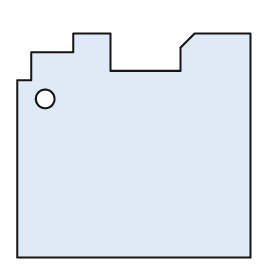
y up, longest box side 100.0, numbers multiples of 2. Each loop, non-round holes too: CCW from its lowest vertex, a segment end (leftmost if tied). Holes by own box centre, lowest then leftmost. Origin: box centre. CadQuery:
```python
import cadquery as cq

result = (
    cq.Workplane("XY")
    .moveTo(-50.0, -48.0)
    .lineTo(50.0, -48.0)
    .lineTo(50.0, 48.0)
    .lineTo(26.0, 48.0)
    .lineTo(20.0, 42.0)
    .lineTo(20.0, 32.0)
    .lineTo(-10.0, 32.0)
    .lineTo(-10.0, 48.0)
    .lineTo(-26.0, 48.0)
    .lineTo(-26.0, 40.0)
    .lineTo(-44.0, 40.0)
    .lineTo(-44.0, 28.0)
    .lineTo(-50.0, 28.0)
    .close()
    .moveTo(-38.0, 20.0)
    .circle(4.0)
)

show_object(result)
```